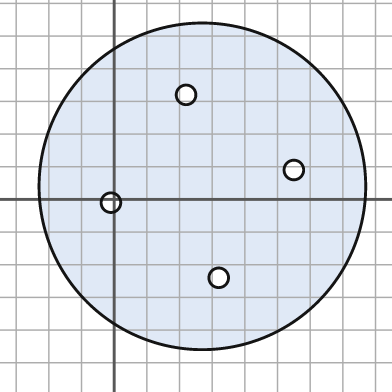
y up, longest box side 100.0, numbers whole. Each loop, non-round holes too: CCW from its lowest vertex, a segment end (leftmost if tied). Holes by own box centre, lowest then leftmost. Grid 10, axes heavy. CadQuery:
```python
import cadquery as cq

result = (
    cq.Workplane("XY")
    .moveTo(27.0, 4.0)
    .circle(50.0)
    .moveTo(32.0, -24.0)
    .circle(3.0)
    .moveTo(-1.0, -1.0)
    .circle(3.0)
    .moveTo(55.0, 9.0)
    .circle(3.0)
    .moveTo(22.0, 32.0)
    .circle(3.0)
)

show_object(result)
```